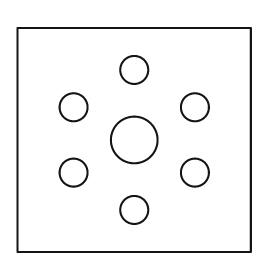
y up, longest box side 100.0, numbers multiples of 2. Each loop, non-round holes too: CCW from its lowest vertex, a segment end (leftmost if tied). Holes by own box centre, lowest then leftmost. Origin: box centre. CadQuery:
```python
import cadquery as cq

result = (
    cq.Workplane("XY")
    .moveTo(-50.0, -48.0)
    .lineTo(50.0, -48.0)
    .lineTo(50.0, 48.0)
    .lineTo(-50.0, 48.0)
    .close()
    .moveTo(0.0, -30.0)
    .circle(6.0)
    .moveTo(-26.0, -14.0)
    .circle(6.0)
    .moveTo(26.0, -14.0)
    .circle(6.0)
    .moveTo(0.0, 0.0)
    .circle(10.0)
    .moveTo(-26.0, 14.0)
    .circle(6.0)
    .moveTo(26.0, 14.0)
    .circle(6.0)
    .moveTo(0.0, 30.0)
    .circle(6.0)
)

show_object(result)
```